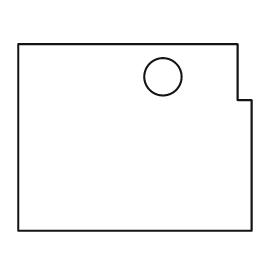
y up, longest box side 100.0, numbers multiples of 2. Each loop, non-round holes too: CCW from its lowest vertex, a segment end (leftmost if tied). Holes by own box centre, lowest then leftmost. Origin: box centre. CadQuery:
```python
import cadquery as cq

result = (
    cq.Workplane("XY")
    .moveTo(-50.0, -40.0)
    .lineTo(50.0, -40.0)
    .lineTo(50.0, 16.0)
    .lineTo(44.0, 16.0)
    .lineTo(44.0, 40.0)
    .lineTo(-50.0, 40.0)
    .close()
    .moveTo(12.0, 26.0)
    .circle(8.0)
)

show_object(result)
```